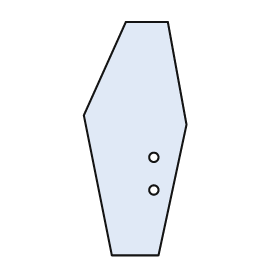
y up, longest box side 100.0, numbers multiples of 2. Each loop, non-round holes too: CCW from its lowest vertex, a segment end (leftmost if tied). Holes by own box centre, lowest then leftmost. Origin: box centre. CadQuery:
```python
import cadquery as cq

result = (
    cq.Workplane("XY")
    .moveTo(-10.0, -50.0)
    .lineTo(10.0, -50.0)
    .lineTo(22.0, 6.0)
    .lineTo(14.0, 50.0)
    .lineTo(-4.0, 50.0)
    .lineTo(-22.0, 10.0)
    .close()
    .moveTo(8.0, -22.0)
    .circle(2.0)
    .moveTo(8.0, -8.0)
    .circle(2.0)
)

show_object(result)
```